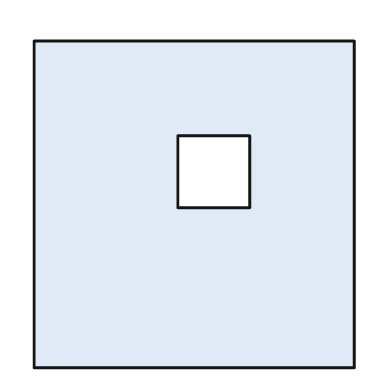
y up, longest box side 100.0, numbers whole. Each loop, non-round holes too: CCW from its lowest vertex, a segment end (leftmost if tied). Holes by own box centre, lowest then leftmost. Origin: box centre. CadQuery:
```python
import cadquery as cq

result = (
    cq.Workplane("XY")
    .moveTo(-49.0, -50.0)
    .lineTo(49.0, -50.0)
    .lineTo(49.0, 50.0)
    .lineTo(-49.0, 50.0)
    .close()
    .moveTo(-5.0, -1.0)
    .lineTo(17.0, -1.0)
    .lineTo(17.0, 21.0)
    .lineTo(-5.0, 21.0)
    .close()
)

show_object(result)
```